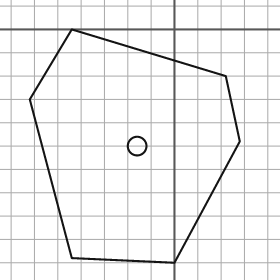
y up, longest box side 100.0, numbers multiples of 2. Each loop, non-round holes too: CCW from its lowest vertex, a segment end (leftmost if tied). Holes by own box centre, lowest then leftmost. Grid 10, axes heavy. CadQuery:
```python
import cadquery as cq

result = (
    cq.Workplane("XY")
    .moveTo(0.0, -100.0)
    .lineTo(28.0, -48.0)
    .lineTo(22.0, -20.0)
    .lineTo(-44.0, 0.0)
    .lineTo(-62.0, -30.0)
    .lineTo(-44.0, -98.0)
    .close()
    .moveTo(-16.0, -50.0)
    .circle(4.0)
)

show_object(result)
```